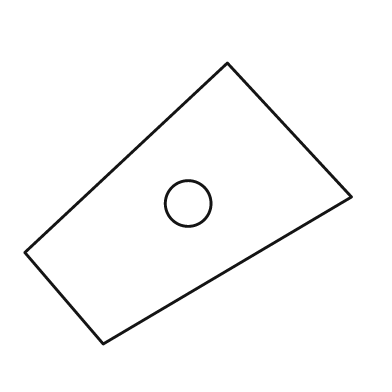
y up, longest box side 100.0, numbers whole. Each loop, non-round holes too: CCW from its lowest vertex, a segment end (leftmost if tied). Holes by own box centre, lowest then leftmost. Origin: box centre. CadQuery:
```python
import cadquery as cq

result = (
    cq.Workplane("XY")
    .moveTo(-26.0, -43.0)
    .lineTo(50.0, 2.0)
    .lineTo(12.0, 43.0)
    .lineTo(-50.0, -15.0)
    .close()
    .moveTo(0.0, 0.0)
    .circle(7.0)
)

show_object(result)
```